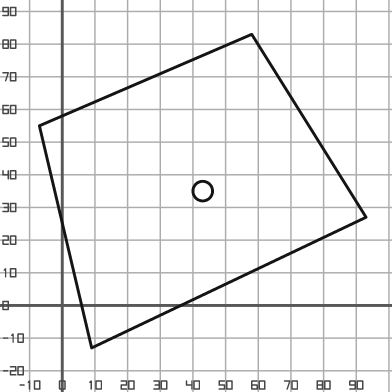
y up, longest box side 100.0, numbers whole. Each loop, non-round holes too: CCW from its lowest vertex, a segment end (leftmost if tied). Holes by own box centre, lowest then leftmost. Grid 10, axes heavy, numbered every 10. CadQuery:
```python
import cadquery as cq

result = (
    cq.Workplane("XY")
    .moveTo(9.0, -13.0)
    .lineTo(93.0, 27.0)
    .lineTo(58.0, 83.0)
    .lineTo(-7.0, 55.0)
    .close()
    .moveTo(43.0, 35.0)
    .circle(3.0)
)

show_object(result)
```